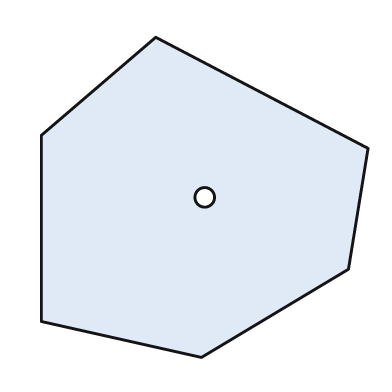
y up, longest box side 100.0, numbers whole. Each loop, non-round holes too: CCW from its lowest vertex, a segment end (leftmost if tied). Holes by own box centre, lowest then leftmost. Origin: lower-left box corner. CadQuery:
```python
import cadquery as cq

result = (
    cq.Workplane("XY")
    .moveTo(49.0, 0.0)
    .lineTo(94.0, 27.0)
    .lineTo(100.0, 64.0)
    .lineTo(35.0, 98.0)
    .lineTo(0.0, 68.0)
    .lineTo(0.0, 11.0)
    .close()
    .moveTo(50.0, 49.0)
    .circle(3.0)
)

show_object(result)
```